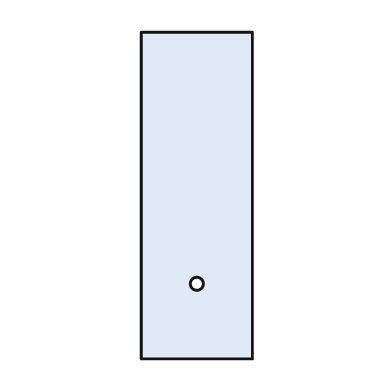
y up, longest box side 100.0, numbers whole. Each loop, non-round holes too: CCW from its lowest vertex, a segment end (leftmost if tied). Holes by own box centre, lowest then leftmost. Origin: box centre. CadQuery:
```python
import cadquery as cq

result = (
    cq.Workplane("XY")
    .moveTo(-17.0, -50.0)
    .lineTo(17.0, -50.0)
    .lineTo(17.0, 50.0)
    .lineTo(-17.0, 50.0)
    .close()
    .moveTo(0.0, -27.0)
    .circle(2.0)
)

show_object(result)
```